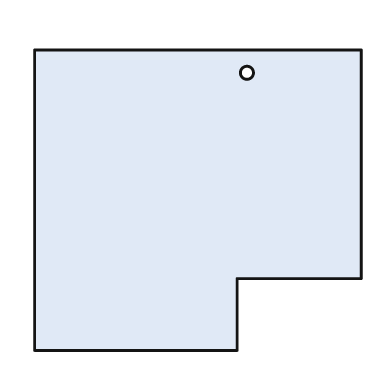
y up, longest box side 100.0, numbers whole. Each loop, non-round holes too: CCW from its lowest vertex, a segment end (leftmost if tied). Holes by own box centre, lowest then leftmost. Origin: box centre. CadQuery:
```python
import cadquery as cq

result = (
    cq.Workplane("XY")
    .moveTo(-50.0, -46.0)
    .lineTo(12.0, -46.0)
    .lineTo(12.0, -24.0)
    .lineTo(50.0, -24.0)
    .lineTo(50.0, 46.0)
    .lineTo(-50.0, 46.0)
    .close()
    .moveTo(15.0, 39.0)
    .circle(2.0)
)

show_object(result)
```